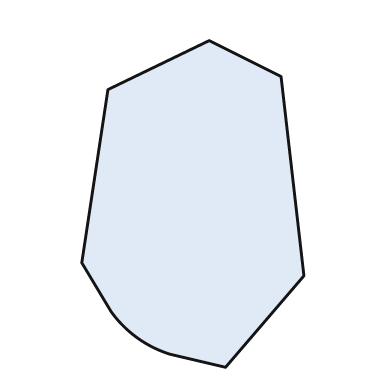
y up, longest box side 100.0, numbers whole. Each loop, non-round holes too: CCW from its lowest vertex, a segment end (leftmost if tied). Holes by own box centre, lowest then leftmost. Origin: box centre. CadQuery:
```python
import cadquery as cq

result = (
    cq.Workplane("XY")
    .moveTo(10.0, -50.0)
    .lineTo(34.0, -22.0)
    .lineTo(27.0, 39.0)
    .lineTo(5.0, 50.0)
    .lineTo(-26.0, 35.0)
    .lineTo(-34.0, -18.0)
    .lineTo(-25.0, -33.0)
    .threePointArc((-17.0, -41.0), (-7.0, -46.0))
    .close()
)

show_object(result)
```